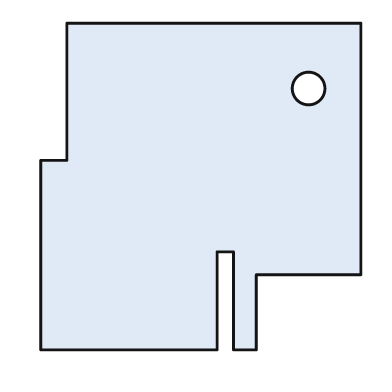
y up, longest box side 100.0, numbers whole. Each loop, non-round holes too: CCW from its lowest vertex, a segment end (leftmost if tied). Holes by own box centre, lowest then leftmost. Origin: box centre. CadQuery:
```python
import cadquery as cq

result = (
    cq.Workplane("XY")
    .moveTo(-49.0, -50.0)
    .lineTo(5.0, -50.0)
    .lineTo(5.0, -20.0)
    .lineTo(10.0, -20.0)
    .lineTo(10.0, -50.0)
    .lineTo(17.0, -50.0)
    .lineTo(17.0, -27.0)
    .lineTo(49.0, -27.0)
    .lineTo(49.0, 50.0)
    .lineTo(-41.0, 50.0)
    .lineTo(-41.0, 8.0)
    .lineTo(-49.0, 8.0)
    .close()
    .moveTo(33.0, 30.0)
    .circle(5.0)
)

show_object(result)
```